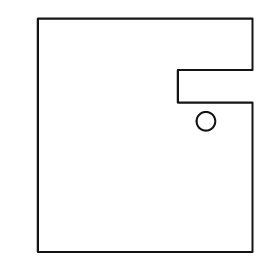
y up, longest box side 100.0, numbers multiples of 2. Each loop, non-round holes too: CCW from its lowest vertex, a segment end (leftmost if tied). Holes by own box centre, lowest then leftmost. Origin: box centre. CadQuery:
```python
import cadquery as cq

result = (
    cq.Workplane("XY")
    .moveTo(-46.0, -50.0)
    .lineTo(46.0, -50.0)
    .lineTo(46.0, 14.0)
    .lineTo(14.0, 14.0)
    .lineTo(14.0, 28.0)
    .lineTo(46.0, 28.0)
    .lineTo(46.0, 50.0)
    .lineTo(-46.0, 50.0)
    .close()
    .moveTo(26.0, 6.0)
    .circle(4.0)
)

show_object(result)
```